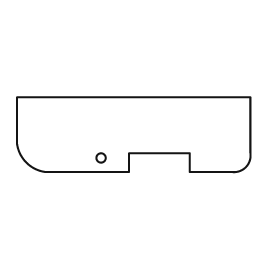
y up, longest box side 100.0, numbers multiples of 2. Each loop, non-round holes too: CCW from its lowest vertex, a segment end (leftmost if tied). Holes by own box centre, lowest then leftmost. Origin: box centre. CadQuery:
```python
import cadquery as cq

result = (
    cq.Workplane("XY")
    .moveTo(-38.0, -16.0)
    .lineTo(-2.0, -16.0)
    .lineTo(-2.0, -8.0)
    .lineTo(24.0, -8.0)
    .lineTo(24.0, -16.0)
    .lineTo(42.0, -16.0)
    .threePointArc((48.0, -14.0), (50.0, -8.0))
    .lineTo(50.0, 16.0)
    .lineTo(-50.0, 16.0)
    .lineTo(-50.0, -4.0)
    .threePointArc((-46.0, -12.0), (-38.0, -16.0))
    .close()
    .moveTo(-14.0, -10.0)
    .circle(2.0)
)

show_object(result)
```